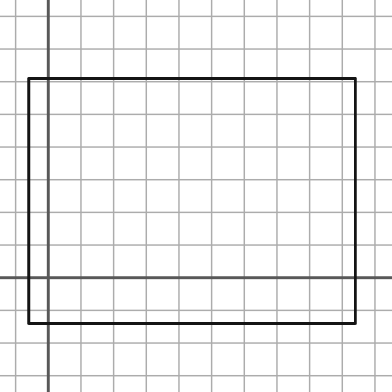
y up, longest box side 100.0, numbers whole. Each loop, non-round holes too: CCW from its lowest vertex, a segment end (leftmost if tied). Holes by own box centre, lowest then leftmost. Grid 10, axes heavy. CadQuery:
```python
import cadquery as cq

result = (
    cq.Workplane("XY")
    .moveTo(-6.0, -14.0)
    .lineTo(94.0, -14.0)
    .lineTo(94.0, 61.0)
    .lineTo(-6.0, 61.0)
    .close()
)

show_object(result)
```